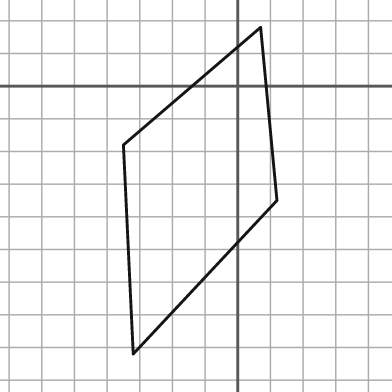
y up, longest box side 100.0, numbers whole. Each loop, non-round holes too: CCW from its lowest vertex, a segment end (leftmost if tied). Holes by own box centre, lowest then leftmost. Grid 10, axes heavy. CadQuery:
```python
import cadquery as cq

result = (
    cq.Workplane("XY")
    .moveTo(-32.0, -82.0)
    .lineTo(12.0, -35.0)
    .lineTo(7.0, 18.0)
    .lineTo(-35.0, -18.0)
    .close()
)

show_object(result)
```